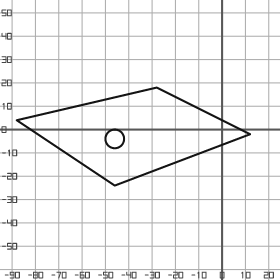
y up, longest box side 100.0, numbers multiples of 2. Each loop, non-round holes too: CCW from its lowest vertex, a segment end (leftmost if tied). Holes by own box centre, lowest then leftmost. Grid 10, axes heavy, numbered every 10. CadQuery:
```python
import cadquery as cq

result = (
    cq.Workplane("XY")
    .moveTo(-46.0, -24.0)
    .lineTo(12.0, -2.0)
    .lineTo(-28.0, 18.0)
    .lineTo(-88.0, 4.0)
    .close()
    .moveTo(-46.0, -4.0)
    .circle(4.0)
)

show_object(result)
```